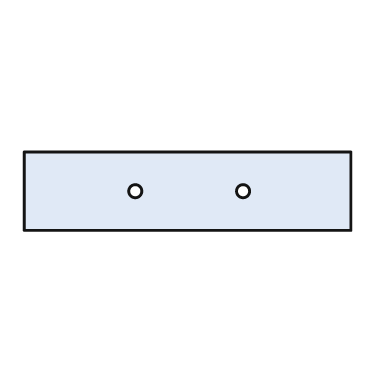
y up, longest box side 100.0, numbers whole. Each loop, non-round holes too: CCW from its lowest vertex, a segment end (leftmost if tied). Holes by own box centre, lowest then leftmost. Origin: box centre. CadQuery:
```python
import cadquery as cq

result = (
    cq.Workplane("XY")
    .moveTo(-50.0, -12.0)
    .lineTo(50.0, -12.0)
    .lineTo(50.0, 12.0)
    .lineTo(-50.0, 12.0)
    .close()
    .moveTo(-16.0, 0.0)
    .circle(2.0)
    .moveTo(17.0, 0.0)
    .circle(2.0)
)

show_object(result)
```